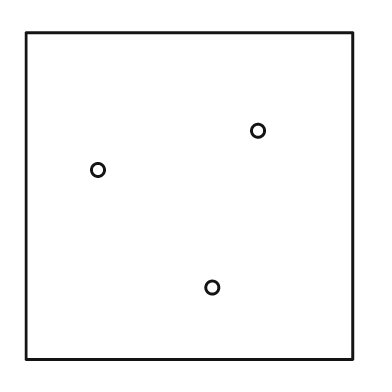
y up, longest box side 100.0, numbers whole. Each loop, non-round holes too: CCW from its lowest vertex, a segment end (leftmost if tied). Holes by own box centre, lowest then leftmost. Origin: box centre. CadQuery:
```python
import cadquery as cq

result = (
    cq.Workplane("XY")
    .moveTo(-50.0, -50.0)
    .lineTo(50.0, -50.0)
    .lineTo(50.0, 50.0)
    .lineTo(-50.0, 50.0)
    .close()
    .moveTo(7.0, -28.0)
    .circle(2.0)
    .moveTo(-28.0, 8.0)
    .circle(2.0)
    .moveTo(21.0, 20.0)
    .circle(2.0)
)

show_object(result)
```